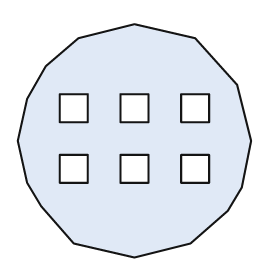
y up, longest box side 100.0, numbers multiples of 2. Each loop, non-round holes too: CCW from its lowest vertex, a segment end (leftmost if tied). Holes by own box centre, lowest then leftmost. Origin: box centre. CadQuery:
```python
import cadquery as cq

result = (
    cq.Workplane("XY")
    .moveTo(0.0, -50.0)
    .lineTo(24.0, -44.0)
    .lineTo(40.0, -30.0)
    .lineTo(46.0, -20.0)
    .lineTo(50.0, 0.0)
    .lineTo(44.0, 24.0)
    .lineTo(26.0, 44.0)
    .lineTo(0.0, 50.0)
    .lineTo(-24.0, 44.0)
    .lineTo(-38.0, 32.0)
    .lineTo(-46.0, 18.0)
    .lineTo(-50.0, 0.0)
    .lineTo(-46.0, -18.0)
    .lineTo(-40.0, -28.0)
    .lineTo(-26.0, -44.0)
    .close()
    .moveTo(-32.0, -18.0)
    .lineTo(-20.0, -18.0)
    .lineTo(-20.0, -6.0)
    .lineTo(-32.0, -6.0)
    .close()
    .moveTo(-6.0, -18.0)
    .lineTo(6.0, -18.0)
    .lineTo(6.0, -6.0)
    .lineTo(-6.0, -6.0)
    .close()
    .moveTo(20.0, -18.0)
    .lineTo(32.0, -18.0)
    .lineTo(32.0, -6.0)
    .lineTo(20.0, -6.0)
    .close()
    .moveTo(-32.0, 8.0)
    .lineTo(-20.0, 8.0)
    .lineTo(-20.0, 20.0)
    .lineTo(-32.0, 20.0)
    .close()
    .moveTo(-6.0, 8.0)
    .lineTo(6.0, 8.0)
    .lineTo(6.0, 20.0)
    .lineTo(-6.0, 20.0)
    .close()
    .moveTo(20.0, 8.0)
    .lineTo(32.0, 8.0)
    .lineTo(32.0, 20.0)
    .lineTo(20.0, 20.0)
    .close()
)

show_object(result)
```